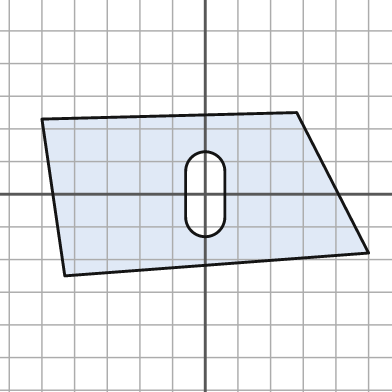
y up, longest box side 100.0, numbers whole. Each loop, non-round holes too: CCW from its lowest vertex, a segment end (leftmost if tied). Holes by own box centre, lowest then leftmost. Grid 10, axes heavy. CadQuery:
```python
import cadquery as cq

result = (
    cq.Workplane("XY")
    .moveTo(-43.0, -25.0)
    .lineTo(50.0, -18.0)
    .lineTo(28.0, 25.0)
    .lineTo(-50.0, 23.0)
    .close()
    .moveTo(-6.0, -7.0)
    .threePointArc((0.0, -13.0), (6.0, -7.0))
    .lineTo(6.0, 7.0)
    .threePointArc((0.0, 13.0), (-6.0, 7.0))
    .close()
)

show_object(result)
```